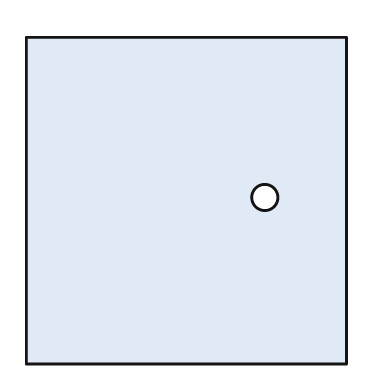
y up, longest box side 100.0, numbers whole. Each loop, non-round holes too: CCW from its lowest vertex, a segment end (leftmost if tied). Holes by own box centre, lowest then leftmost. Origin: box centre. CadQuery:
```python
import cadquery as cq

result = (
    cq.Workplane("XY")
    .moveTo(-49.0, -50.0)
    .lineTo(49.0, -50.0)
    .lineTo(49.0, 50.0)
    .lineTo(-49.0, 50.0)
    .close()
    .moveTo(24.0, 1.0)
    .circle(4.0)
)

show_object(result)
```